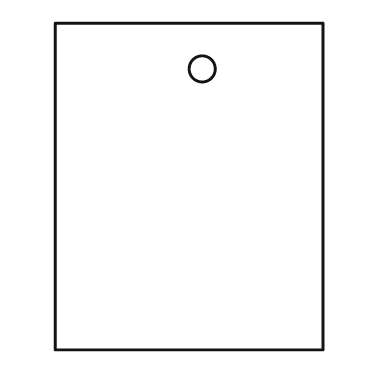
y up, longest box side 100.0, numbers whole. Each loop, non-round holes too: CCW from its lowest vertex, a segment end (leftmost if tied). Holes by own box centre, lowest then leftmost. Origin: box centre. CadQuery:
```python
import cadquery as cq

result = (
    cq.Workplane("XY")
    .moveTo(-41.0, -50.0)
    .lineTo(41.0, -50.0)
    .lineTo(41.0, 50.0)
    .lineTo(-41.0, 50.0)
    .close()
    .moveTo(4.0, 36.0)
    .circle(4.0)
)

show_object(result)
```